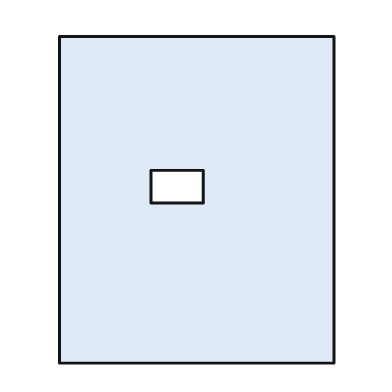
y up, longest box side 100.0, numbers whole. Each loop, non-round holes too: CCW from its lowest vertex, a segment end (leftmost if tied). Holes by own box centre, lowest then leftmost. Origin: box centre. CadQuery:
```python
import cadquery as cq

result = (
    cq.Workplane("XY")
    .moveTo(-42.0, -50.0)
    .lineTo(42.0, -50.0)
    .lineTo(42.0, 50.0)
    .lineTo(-42.0, 50.0)
    .close()
    .moveTo(-14.0, -1.0)
    .lineTo(2.0, -1.0)
    .lineTo(2.0, 9.0)
    .lineTo(-14.0, 9.0)
    .close()
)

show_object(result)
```